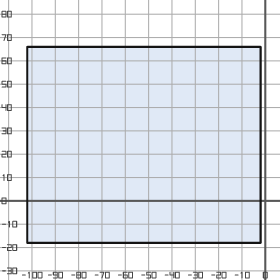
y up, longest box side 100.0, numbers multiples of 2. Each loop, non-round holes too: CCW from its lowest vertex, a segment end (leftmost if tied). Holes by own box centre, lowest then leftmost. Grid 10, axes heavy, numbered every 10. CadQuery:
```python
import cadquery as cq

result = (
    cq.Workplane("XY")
    .moveTo(-102.0, -18.0)
    .lineTo(-2.0, -18.0)
    .lineTo(-2.0, 66.0)
    .lineTo(-102.0, 66.0)
    .close()
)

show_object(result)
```